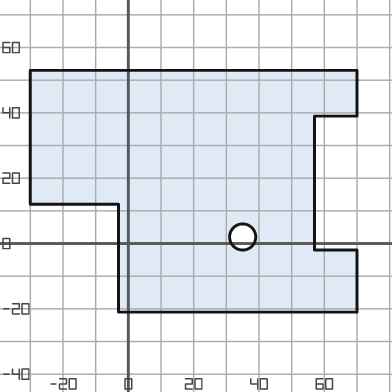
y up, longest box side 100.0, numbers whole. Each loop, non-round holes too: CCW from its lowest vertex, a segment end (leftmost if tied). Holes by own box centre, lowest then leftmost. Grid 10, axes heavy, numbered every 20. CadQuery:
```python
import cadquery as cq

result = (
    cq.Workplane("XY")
    .moveTo(-3.0, -21.0)
    .lineTo(70.0, -21.0)
    .lineTo(70.0, -2.0)
    .lineTo(57.0, -2.0)
    .lineTo(57.0, 39.0)
    .lineTo(70.0, 39.0)
    .lineTo(70.0, 53.0)
    .lineTo(-30.0, 53.0)
    .lineTo(-30.0, 12.0)
    .lineTo(-3.0, 12.0)
    .close()
    .moveTo(35.0, 2.0)
    .circle(4.0)
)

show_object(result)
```